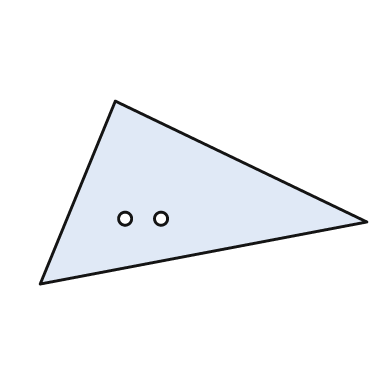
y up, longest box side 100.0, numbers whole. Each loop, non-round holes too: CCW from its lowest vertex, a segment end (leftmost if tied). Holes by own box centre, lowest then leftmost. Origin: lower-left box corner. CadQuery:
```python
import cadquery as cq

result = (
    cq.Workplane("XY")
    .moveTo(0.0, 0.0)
    .lineTo(100.0, 19.0)
    .lineTo(23.0, 56.0)
    .close()
    .moveTo(26.0, 20.0)
    .circle(2.0)
    .moveTo(37.0, 20.0)
    .circle(2.0)
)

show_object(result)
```